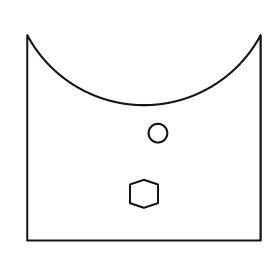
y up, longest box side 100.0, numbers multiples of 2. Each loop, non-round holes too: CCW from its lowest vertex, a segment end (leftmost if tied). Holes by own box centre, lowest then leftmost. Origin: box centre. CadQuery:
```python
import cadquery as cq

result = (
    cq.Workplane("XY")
    .moveTo(-50.0, -44.0)
    .lineTo(50.0, -44.0)
    .lineTo(50.0, 44.0)
    .threePointArc((0.0, 14.0), (-50.0, 44.0))
    .close()
    .moveTo(0.0, -30.0)
    .lineTo(6.0, -28.0)
    .lineTo(6.0, -20.0)
    .lineTo(0.0, -18.0)
    .lineTo(-6.0, -20.0)
    .lineTo(-6.0, -28.0)
    .close()
    .moveTo(6.0, 2.0)
    .circle(4.0)
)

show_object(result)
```